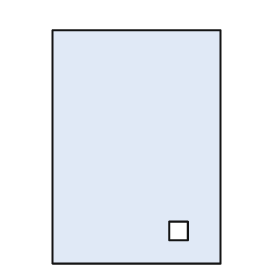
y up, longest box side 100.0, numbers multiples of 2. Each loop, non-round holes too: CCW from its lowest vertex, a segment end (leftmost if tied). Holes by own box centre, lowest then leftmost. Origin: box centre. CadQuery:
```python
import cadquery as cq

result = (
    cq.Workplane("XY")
    .moveTo(-36.0, -50.0)
    .lineTo(36.0, -50.0)
    .lineTo(36.0, 50.0)
    .lineTo(-36.0, 50.0)
    .close()
    .moveTo(14.0, -40.0)
    .lineTo(22.0, -40.0)
    .lineTo(22.0, -32.0)
    .lineTo(14.0, -32.0)
    .close()
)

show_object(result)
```